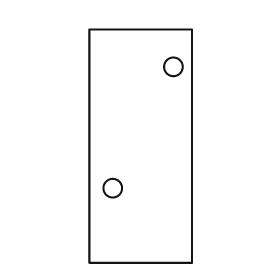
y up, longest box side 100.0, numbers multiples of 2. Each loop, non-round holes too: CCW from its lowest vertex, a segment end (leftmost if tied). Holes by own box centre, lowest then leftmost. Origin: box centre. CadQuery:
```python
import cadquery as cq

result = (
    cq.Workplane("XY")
    .moveTo(-22.0, -50.0)
    .lineTo(22.0, -50.0)
    .lineTo(22.0, 50.0)
    .lineTo(-22.0, 50.0)
    .close()
    .moveTo(-12.0, -18.0)
    .circle(4.0)
    .moveTo(14.0, 34.0)
    .circle(4.0)
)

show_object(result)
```